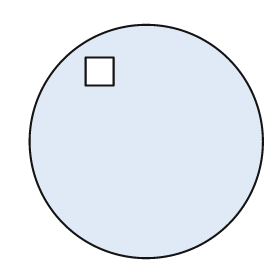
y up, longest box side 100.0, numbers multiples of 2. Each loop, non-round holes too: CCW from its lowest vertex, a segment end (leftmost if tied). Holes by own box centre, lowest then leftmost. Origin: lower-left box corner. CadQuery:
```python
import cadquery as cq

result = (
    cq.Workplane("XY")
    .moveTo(50.0, 50.0)
    .circle(50.0)
    .moveTo(24.0, 74.0)
    .lineTo(36.0, 74.0)
    .lineTo(36.0, 86.0)
    .lineTo(24.0, 86.0)
    .close()
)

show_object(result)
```